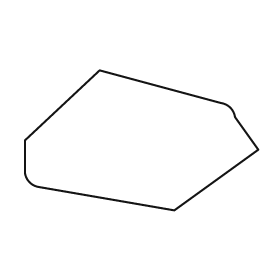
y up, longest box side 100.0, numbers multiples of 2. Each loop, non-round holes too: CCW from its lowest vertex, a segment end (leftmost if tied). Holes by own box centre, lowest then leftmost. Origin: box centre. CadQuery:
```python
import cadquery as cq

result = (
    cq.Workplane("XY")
    .moveTo(14.0, -30.0)
    .lineTo(50.0, -4.0)
    .lineTo(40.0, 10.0)
    .threePointArc((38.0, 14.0), (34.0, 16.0))
    .lineTo(-18.0, 30.0)
    .lineTo(-50.0, 0.0)
    .lineTo(-50.0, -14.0)
    .threePointArc((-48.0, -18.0), (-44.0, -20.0))
    .close()
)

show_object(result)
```